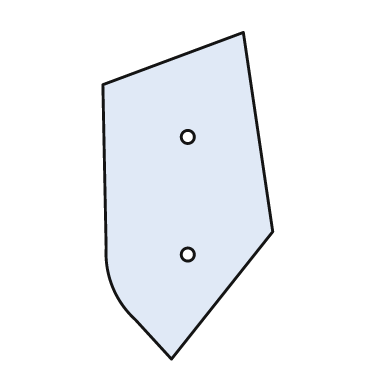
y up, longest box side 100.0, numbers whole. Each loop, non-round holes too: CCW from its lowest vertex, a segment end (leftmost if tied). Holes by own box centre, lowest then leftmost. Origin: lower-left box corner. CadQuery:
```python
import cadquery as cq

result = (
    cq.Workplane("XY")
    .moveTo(21.0, 0.0)
    .lineTo(52.0, 39.0)
    .lineTo(43.0, 100.0)
    .lineTo(0.0, 84.0)
    .lineTo(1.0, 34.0)
    .threePointArc((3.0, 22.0), (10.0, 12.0))
    .close()
    .moveTo(26.0, 32.0)
    .circle(2.0)
    .moveTo(26.0, 68.0)
    .circle(2.0)
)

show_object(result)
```